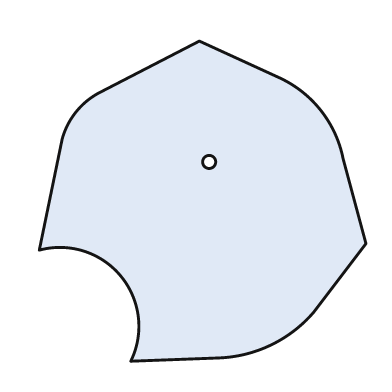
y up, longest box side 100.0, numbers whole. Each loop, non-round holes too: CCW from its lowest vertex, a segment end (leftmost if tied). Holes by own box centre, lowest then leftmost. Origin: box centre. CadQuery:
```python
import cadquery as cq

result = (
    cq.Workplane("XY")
    .moveTo(-22.0, -49.0)
    .lineTo(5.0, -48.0)
    .threePointArc((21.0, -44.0), (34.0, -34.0))
    .lineTo(50.0, -13.0)
    .lineTo(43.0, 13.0)
    .threePointArc((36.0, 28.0), (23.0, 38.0))
    .lineTo(-1.0, 49.0)
    .lineTo(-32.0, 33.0)
    .threePointArc((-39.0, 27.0), (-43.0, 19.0))
    .lineTo(-50.0, -15.0)
    .threePointArc((-25.0, -23.0), (-22.0, -49.0))
    .close()
    .moveTo(2.0, 12.0)
    .circle(2.0)
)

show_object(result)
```